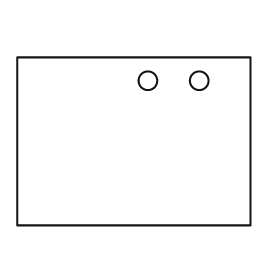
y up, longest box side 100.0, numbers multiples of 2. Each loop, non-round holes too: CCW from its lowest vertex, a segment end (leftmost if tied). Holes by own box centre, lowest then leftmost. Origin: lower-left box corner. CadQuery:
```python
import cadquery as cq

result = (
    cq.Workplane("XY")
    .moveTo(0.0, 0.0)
    .lineTo(100.0, 0.0)
    .lineTo(100.0, 72.0)
    .lineTo(0.0, 72.0)
    .close()
    .moveTo(56.0, 62.0)
    .circle(4.0)
    .moveTo(78.0, 62.0)
    .circle(4.0)
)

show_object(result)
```